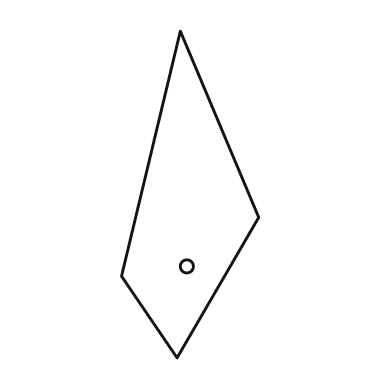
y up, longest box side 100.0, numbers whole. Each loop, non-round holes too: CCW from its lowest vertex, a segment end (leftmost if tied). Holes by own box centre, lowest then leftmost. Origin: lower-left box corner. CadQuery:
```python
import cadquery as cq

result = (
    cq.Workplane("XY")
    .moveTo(17.0, 0.0)
    .lineTo(42.0, 43.0)
    .lineTo(18.0, 100.0)
    .lineTo(0.0, 25.0)
    .close()
    .moveTo(20.0, 28.0)
    .circle(2.0)
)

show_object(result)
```